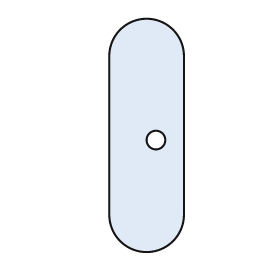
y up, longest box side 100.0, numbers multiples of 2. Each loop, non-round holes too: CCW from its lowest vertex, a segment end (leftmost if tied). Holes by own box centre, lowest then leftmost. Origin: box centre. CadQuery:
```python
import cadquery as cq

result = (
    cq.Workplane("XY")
    .moveTo(-16.0, -34.0)
    .threePointArc((0.0, -50.0), (16.0, -34.0))
    .lineTo(16.0, 34.0)
    .threePointArc((0.0, 50.0), (-16.0, 34.0))
    .close()
    .moveTo(4.0, -2.0)
    .circle(4.0)
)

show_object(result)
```